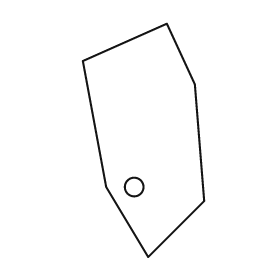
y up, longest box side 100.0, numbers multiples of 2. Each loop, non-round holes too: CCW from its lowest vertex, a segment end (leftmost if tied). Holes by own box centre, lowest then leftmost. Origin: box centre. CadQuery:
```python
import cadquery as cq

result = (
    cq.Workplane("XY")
    .moveTo(2.0, -50.0)
    .lineTo(26.0, -26.0)
    .lineTo(22.0, 24.0)
    .lineTo(10.0, 50.0)
    .lineTo(-26.0, 34.0)
    .lineTo(-16.0, -20.0)
    .close()
    .moveTo(-4.0, -20.0)
    .circle(4.0)
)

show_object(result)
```